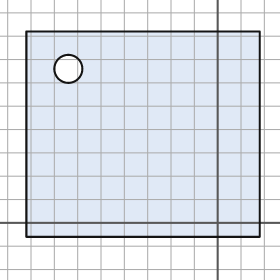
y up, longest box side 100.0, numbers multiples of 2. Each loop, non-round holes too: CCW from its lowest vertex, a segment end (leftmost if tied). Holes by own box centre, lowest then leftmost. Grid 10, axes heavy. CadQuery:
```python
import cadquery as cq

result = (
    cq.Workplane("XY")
    .moveTo(-82.0, -6.0)
    .lineTo(18.0, -6.0)
    .lineTo(18.0, 82.0)
    .lineTo(-82.0, 82.0)
    .close()
    .moveTo(-64.0, 66.0)
    .circle(6.0)
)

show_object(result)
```